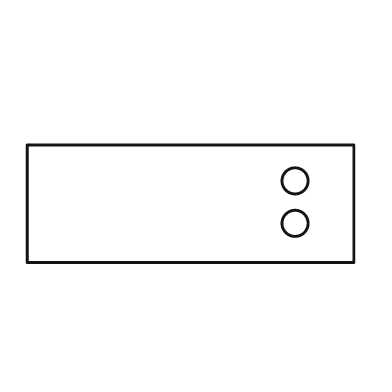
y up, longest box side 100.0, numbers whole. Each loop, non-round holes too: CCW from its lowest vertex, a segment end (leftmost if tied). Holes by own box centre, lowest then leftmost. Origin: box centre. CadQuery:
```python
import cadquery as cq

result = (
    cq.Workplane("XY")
    .moveTo(-50.0, -18.0)
    .lineTo(50.0, -18.0)
    .lineTo(50.0, 18.0)
    .lineTo(-50.0, 18.0)
    .close()
    .moveTo(32.0, -6.0)
    .circle(4.0)
    .moveTo(32.0, 7.0)
    .circle(4.0)
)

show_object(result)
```